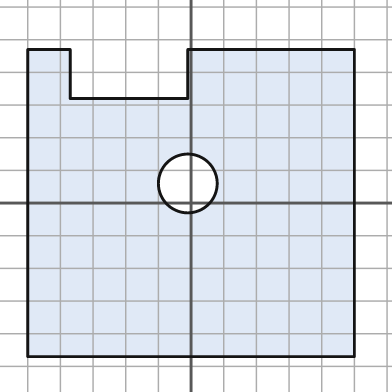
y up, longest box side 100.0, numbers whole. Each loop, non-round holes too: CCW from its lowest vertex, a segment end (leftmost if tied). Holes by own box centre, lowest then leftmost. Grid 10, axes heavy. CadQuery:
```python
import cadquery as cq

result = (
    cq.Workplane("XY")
    .moveTo(-50.0, -47.0)
    .lineTo(50.0, -47.0)
    .lineTo(50.0, 47.0)
    .lineTo(-1.0, 47.0)
    .lineTo(-1.0, 32.0)
    .lineTo(-37.0, 32.0)
    .lineTo(-37.0, 47.0)
    .lineTo(-50.0, 47.0)
    .close()
    .moveTo(-1.0, 6.0)
    .circle(9.0)
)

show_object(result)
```